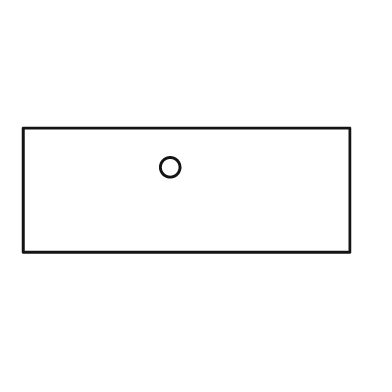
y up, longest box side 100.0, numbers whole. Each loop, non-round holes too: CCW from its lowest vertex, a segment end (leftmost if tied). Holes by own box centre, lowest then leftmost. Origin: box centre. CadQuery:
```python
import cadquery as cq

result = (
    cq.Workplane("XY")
    .moveTo(-50.0, -19.0)
    .lineTo(50.0, -19.0)
    .lineTo(50.0, 19.0)
    .lineTo(-50.0, 19.0)
    .close()
    .moveTo(-5.0, 7.0)
    .circle(3.0)
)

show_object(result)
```